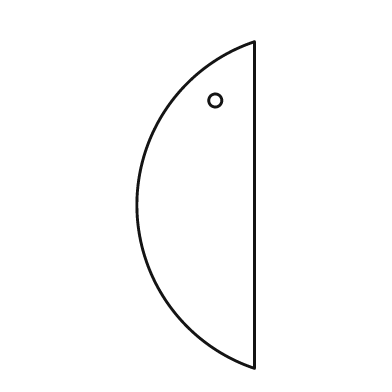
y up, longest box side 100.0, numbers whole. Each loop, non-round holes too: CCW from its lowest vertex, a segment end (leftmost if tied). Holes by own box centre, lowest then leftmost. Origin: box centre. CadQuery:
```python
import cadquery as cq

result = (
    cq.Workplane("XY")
    .moveTo(18.0, -50.0)
    .lineTo(18.0, 50.0)
    .threePointArc((-18.0, 0.0), (18.0, -50.0))
    .close()
    .moveTo(6.0, 32.0)
    .circle(2.0)
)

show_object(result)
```